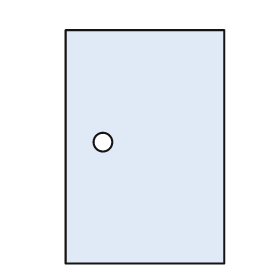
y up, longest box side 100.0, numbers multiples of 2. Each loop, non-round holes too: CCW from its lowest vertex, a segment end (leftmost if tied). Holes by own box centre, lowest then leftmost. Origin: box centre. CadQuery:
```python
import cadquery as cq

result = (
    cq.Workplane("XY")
    .moveTo(-34.0, -50.0)
    .lineTo(34.0, -50.0)
    .lineTo(34.0, 50.0)
    .lineTo(-34.0, 50.0)
    .close()
    .moveTo(-18.0, 2.0)
    .circle(4.0)
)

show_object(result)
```